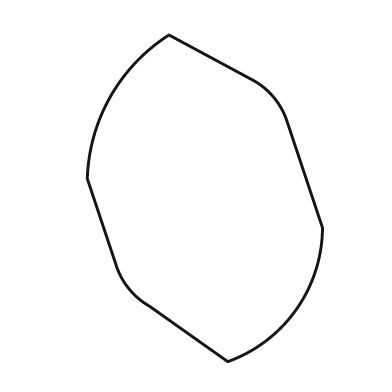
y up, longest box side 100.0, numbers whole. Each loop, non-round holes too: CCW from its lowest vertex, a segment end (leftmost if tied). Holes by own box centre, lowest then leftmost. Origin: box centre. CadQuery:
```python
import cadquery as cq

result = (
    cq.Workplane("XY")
    .moveTo(7.0, -50.0)
    .threePointArc((28.0, -34.0), (36.0, -9.0))
    .lineTo(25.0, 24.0)
    .threePointArc((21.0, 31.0), (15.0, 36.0))
    .lineTo(-11.0, 50.0)
    .threePointArc((-29.0, 31.0), (-36.0, 6.0))
    .lineTo(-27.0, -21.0)
    .threePointArc((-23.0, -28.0), (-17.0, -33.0))
    .close()
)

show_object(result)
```